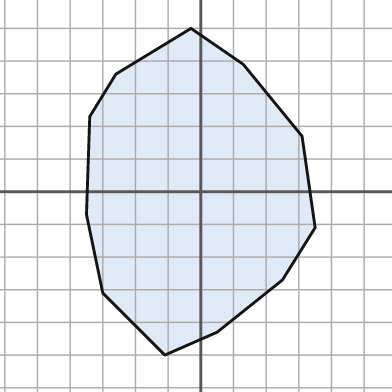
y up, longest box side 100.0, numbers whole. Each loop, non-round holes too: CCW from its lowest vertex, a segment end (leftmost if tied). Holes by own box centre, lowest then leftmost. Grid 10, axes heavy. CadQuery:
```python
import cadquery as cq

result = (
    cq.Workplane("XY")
    .moveTo(-11.0, -50.0)
    .lineTo(5.0, -43.0)
    .lineTo(25.0, -27.0)
    .lineTo(35.0, -11.0)
    .lineTo(31.0, 17.0)
    .lineTo(13.0, 39.0)
    .lineTo(-3.0, 50.0)
    .lineTo(-26.0, 36.0)
    .lineTo(-34.0, 23.0)
    .lineTo(-35.0, -7.0)
    .lineTo(-30.0, -31.0)
    .close()
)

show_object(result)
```